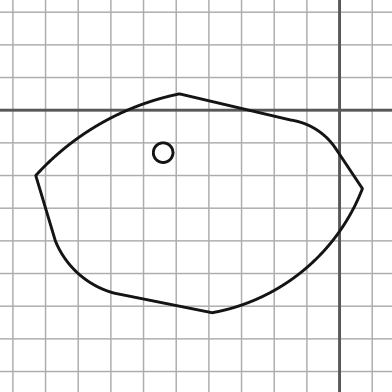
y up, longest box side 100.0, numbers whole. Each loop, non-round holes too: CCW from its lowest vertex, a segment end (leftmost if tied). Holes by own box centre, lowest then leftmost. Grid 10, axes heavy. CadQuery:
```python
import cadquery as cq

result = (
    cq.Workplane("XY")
    .moveTo(-39.0, -62.0)
    .threePointArc((-11.0, -49.0), (7.0, -24.0))
    .lineTo(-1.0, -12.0)
    .threePointArc((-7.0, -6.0), (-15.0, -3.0))
    .lineTo(-49.0, 5.0)
    .threePointArc((-73.0, -4.0), (-93.0, -20.0))
    .lineTo(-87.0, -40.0)
    .threePointArc((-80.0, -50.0), (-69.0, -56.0))
    .close()
    .moveTo(-54.0, -13.0)
    .circle(3.0)
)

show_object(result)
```